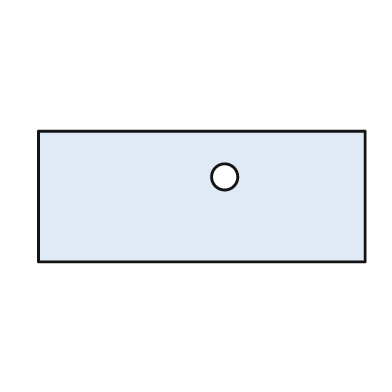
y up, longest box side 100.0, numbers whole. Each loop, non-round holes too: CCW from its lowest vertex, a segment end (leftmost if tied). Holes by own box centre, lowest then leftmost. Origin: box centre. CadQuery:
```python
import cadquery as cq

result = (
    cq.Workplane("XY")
    .moveTo(-50.0, -20.0)
    .lineTo(50.0, -20.0)
    .lineTo(50.0, 20.0)
    .lineTo(-50.0, 20.0)
    .close()
    .moveTo(7.0, 6.0)
    .circle(4.0)
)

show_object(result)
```